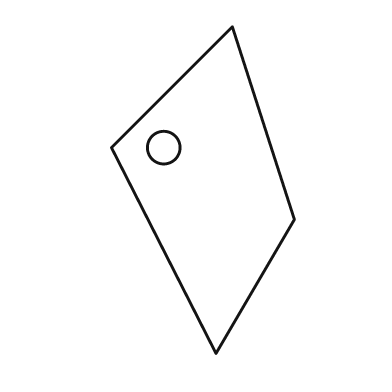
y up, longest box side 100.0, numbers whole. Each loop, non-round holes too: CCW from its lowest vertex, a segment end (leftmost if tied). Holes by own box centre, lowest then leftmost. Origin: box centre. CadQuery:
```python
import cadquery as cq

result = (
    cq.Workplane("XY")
    .moveTo(4.0, -50.0)
    .lineTo(28.0, -9.0)
    .lineTo(9.0, 50.0)
    .lineTo(-28.0, 13.0)
    .close()
    .moveTo(-12.0, 13.0)
    .circle(5.0)
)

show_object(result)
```